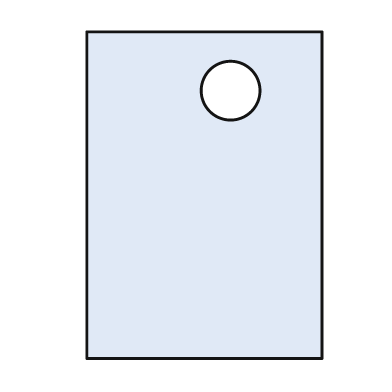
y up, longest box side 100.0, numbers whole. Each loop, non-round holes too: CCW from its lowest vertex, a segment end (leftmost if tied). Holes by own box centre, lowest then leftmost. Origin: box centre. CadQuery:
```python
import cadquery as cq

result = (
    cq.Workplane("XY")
    .moveTo(-36.0, -50.0)
    .lineTo(36.0, -50.0)
    .lineTo(36.0, 50.0)
    .lineTo(-36.0, 50.0)
    .close()
    .moveTo(8.0, 32.0)
    .circle(9.0)
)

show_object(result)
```